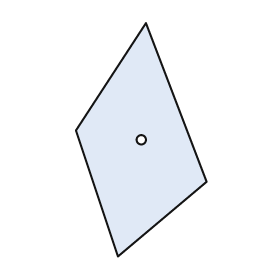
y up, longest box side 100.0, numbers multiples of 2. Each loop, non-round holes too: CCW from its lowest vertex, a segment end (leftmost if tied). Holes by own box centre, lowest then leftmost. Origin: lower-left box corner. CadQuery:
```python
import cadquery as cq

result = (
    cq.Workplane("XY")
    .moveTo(18.0, 0.0)
    .lineTo(56.0, 32.0)
    .lineTo(30.0, 100.0)
    .lineTo(0.0, 54.0)
    .close()
    .moveTo(28.0, 50.0)
    .circle(2.0)
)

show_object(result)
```